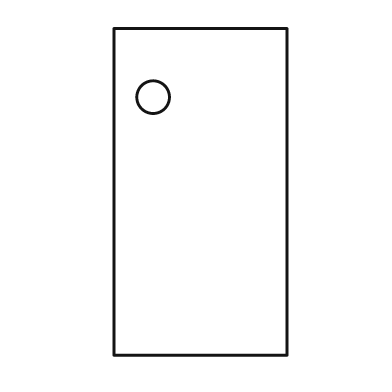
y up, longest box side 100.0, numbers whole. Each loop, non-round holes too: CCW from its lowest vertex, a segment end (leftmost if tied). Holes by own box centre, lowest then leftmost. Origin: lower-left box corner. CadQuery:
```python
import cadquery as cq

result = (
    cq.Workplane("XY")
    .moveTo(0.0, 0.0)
    .lineTo(53.0, 0.0)
    .lineTo(53.0, 100.0)
    .lineTo(0.0, 100.0)
    .close()
    .moveTo(12.0, 79.0)
    .circle(5.0)
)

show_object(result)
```